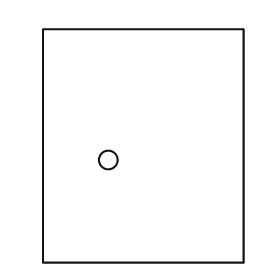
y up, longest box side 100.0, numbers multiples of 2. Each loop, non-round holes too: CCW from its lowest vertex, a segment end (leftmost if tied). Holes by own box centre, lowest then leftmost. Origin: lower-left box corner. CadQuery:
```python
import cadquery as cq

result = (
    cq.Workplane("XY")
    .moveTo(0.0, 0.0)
    .lineTo(86.0, 0.0)
    .lineTo(86.0, 100.0)
    .lineTo(0.0, 100.0)
    .close()
    .moveTo(28.0, 44.0)
    .circle(4.0)
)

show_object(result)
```